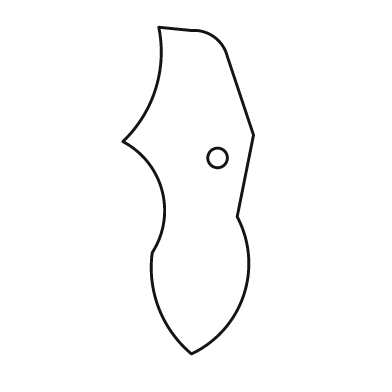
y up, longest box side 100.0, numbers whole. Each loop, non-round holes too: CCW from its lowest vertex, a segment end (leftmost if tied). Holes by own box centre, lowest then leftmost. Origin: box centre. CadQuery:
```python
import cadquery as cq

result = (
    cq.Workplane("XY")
    .moveTo(1.0, -50.0)
    .threePointArc((17.0, -32.0), (15.0, -8.0))
    .lineTo(20.0, 17.0)
    .lineTo(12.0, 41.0)
    .threePointArc((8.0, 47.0), (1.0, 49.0))
    .lineTo(-9.0, 50.0)
    .threePointArc((-10.0, 31.0), (-20.0, 15.0))
    .threePointArc((-8.0, 0.0), (-11.0, -19.0))
    .threePointArc((-9.0, -36.0), (1.0, -50.0))
    .close()
    .moveTo(9.0, 10.0)
    .circle(3.0)
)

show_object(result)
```